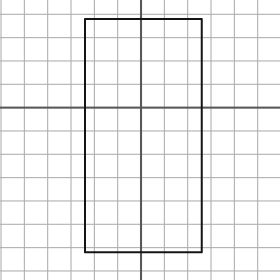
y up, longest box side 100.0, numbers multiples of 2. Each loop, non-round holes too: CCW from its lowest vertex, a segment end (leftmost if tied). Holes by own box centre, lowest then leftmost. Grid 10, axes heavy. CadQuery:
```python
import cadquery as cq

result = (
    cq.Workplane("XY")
    .moveTo(-24.0, -62.0)
    .lineTo(26.0, -62.0)
    .lineTo(26.0, 38.0)
    .lineTo(-24.0, 38.0)
    .close()
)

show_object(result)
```